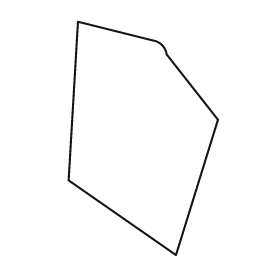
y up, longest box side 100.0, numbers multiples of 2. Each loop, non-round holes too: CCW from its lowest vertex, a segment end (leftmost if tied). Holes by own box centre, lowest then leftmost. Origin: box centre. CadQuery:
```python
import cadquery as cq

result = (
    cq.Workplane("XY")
    .moveTo(14.0, -50.0)
    .lineTo(32.0, 8.0)
    .lineTo(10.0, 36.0)
    .threePointArc((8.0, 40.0), (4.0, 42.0))
    .lineTo(-28.0, 50.0)
    .lineTo(-32.0, -18.0)
    .close()
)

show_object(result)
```